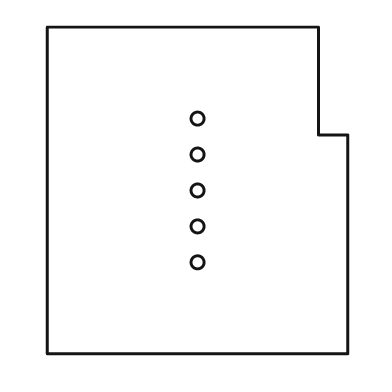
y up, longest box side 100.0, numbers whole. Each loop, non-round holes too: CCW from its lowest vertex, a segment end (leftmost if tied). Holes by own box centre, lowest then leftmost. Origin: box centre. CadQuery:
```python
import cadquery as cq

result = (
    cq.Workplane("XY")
    .moveTo(-46.0, -50.0)
    .lineTo(46.0, -50.0)
    .lineTo(46.0, 17.0)
    .lineTo(37.0, 17.0)
    .lineTo(37.0, 50.0)
    .lineTo(-46.0, 50.0)
    .close()
    .moveTo(0.0, -22.0)
    .circle(2.0)
    .moveTo(0.0, -11.0)
    .circle(2.0)
    .moveTo(0.0, 0.0)
    .circle(2.0)
    .moveTo(0.0, 11.0)
    .circle(2.0)
    .moveTo(0.0, 22.0)
    .circle(2.0)
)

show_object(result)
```